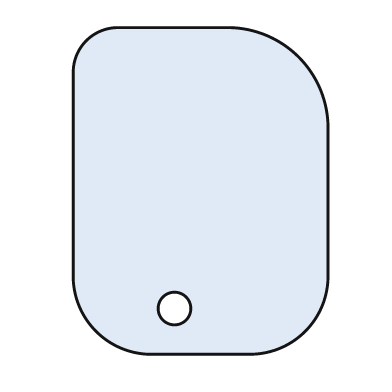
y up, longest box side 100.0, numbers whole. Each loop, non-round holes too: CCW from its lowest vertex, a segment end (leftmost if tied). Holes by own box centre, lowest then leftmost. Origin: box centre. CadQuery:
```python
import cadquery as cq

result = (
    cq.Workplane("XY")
    .moveTo(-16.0, -50.0)
    .lineTo(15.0, -50.0)
    .threePointArc((32.0, -43.0), (39.0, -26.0))
    .lineTo(39.0, 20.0)
    .threePointArc((30.0, 41.0), (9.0, 50.0))
    .lineTo(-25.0, 50.0)
    .threePointArc((-35.0, 46.0), (-39.0, 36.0))
    .lineTo(-39.0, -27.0)
    .threePointArc((-32.0, -43.0), (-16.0, -50.0))
    .close()
    .moveTo(-8.0, -36.0)
    .circle(5.0)
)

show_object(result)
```